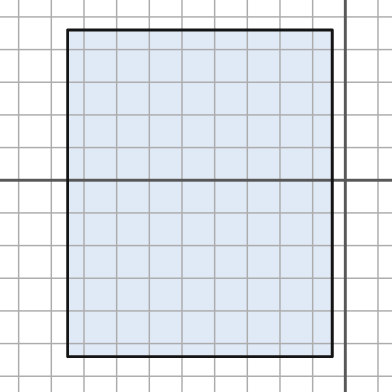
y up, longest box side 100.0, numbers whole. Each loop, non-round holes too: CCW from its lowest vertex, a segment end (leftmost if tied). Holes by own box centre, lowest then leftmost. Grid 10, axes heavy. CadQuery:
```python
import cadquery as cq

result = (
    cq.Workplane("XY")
    .moveTo(-85.0, -54.0)
    .lineTo(-4.0, -54.0)
    .lineTo(-4.0, 46.0)
    .lineTo(-85.0, 46.0)
    .close()
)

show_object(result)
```